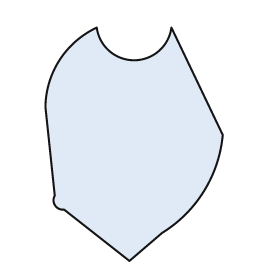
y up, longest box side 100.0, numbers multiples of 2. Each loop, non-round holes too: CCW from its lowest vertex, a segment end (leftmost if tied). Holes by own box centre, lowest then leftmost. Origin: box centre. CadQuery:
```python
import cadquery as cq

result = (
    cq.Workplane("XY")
    .moveTo(-2.0, -50.0)
    .lineTo(12.0, -38.0)
    .threePointArc((30.0, -20.0), (38.0, 4.0))
    .lineTo(16.0, 50.0)
    .threePointArc((0.0, 36.0), (-16.0, 50.0))
    .threePointArc((-32.0, 36.0), (-38.0, 16.0))
    .lineTo(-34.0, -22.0)
    .threePointArc((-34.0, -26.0), (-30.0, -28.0))
    .close()
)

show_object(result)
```